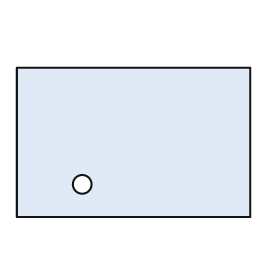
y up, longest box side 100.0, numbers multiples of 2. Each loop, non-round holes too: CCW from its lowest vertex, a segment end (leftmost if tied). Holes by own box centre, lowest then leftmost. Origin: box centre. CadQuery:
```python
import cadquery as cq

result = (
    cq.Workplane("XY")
    .moveTo(-50.0, -32.0)
    .lineTo(50.0, -32.0)
    .lineTo(50.0, 32.0)
    .lineTo(-50.0, 32.0)
    .close()
    .moveTo(-22.0, -18.0)
    .circle(4.0)
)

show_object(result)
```